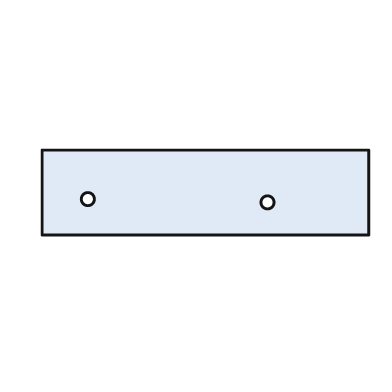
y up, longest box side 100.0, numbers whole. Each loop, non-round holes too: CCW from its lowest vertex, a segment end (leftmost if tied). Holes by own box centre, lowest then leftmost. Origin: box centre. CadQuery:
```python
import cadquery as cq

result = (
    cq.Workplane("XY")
    .moveTo(-50.0, -13.0)
    .lineTo(50.0, -13.0)
    .lineTo(50.0, 13.0)
    .lineTo(-50.0, 13.0)
    .close()
    .moveTo(19.0, -3.0)
    .circle(2.0)
    .moveTo(-36.0, -2.0)
    .circle(2.0)
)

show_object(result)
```